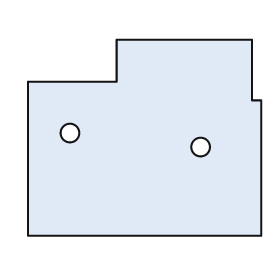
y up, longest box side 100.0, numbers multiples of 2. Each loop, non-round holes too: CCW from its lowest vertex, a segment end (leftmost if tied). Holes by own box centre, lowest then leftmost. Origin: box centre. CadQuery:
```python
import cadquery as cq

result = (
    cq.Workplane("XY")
    .moveTo(-50.0, -42.0)
    .lineTo(50.0, -42.0)
    .lineTo(50.0, 16.0)
    .lineTo(46.0, 16.0)
    .lineTo(46.0, 42.0)
    .lineTo(-12.0, 42.0)
    .lineTo(-12.0, 24.0)
    .lineTo(-50.0, 24.0)
    .close()
    .moveTo(24.0, -4.0)
    .circle(4.0)
    .moveTo(-32.0, 2.0)
    .circle(4.0)
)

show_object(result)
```